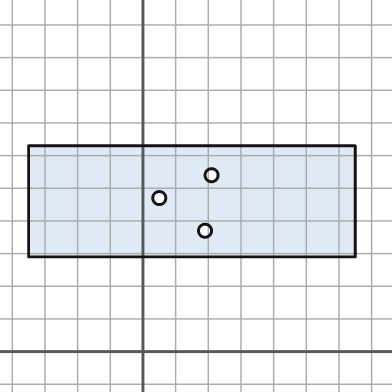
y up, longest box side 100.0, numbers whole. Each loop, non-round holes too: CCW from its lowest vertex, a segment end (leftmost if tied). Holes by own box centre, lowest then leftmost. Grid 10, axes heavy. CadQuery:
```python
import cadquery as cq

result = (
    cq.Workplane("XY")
    .moveTo(-35.0, 29.0)
    .lineTo(65.0, 29.0)
    .lineTo(65.0, 63.0)
    .lineTo(-35.0, 63.0)
    .close()
    .moveTo(19.0, 37.0)
    .circle(2.0)
    .moveTo(5.0, 47.0)
    .circle(2.0)
    .moveTo(21.0, 54.0)
    .circle(2.0)
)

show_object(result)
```